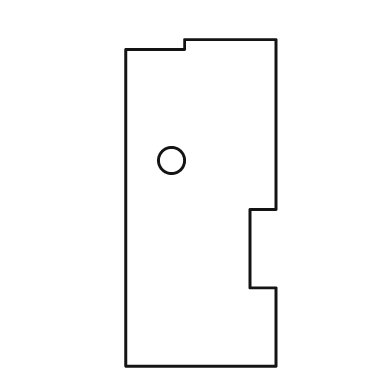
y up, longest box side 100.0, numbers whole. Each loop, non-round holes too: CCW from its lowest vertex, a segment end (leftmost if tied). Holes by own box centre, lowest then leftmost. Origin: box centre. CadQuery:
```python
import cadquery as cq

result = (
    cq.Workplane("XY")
    .moveTo(-23.0, -50.0)
    .lineTo(23.0, -50.0)
    .lineTo(23.0, -26.0)
    .lineTo(15.0, -26.0)
    .lineTo(15.0, -2.0)
    .lineTo(23.0, -2.0)
    .lineTo(23.0, 50.0)
    .lineTo(-5.0, 50.0)
    .lineTo(-5.0, 47.0)
    .lineTo(-23.0, 47.0)
    .close()
    .moveTo(-9.0, 13.0)
    .circle(4.0)
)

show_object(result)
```